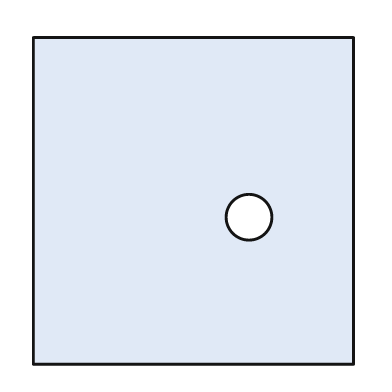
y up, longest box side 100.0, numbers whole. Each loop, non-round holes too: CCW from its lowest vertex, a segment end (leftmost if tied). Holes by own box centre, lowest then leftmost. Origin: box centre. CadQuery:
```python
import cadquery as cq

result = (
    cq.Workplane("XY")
    .moveTo(-49.0, -50.0)
    .lineTo(49.0, -50.0)
    .lineTo(49.0, 50.0)
    .lineTo(-49.0, 50.0)
    .close()
    .moveTo(17.0, -5.0)
    .circle(7.0)
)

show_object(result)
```